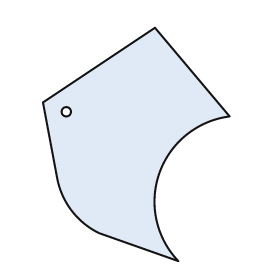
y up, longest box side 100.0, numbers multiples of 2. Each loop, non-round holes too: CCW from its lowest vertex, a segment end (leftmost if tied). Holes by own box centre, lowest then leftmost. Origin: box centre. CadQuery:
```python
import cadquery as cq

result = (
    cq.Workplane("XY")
    .moveTo(18.0, -50.0)
    .threePointArc((10.0, -12.0), (40.0, 12.0))
    .lineTo(8.0, 50.0)
    .lineTo(-40.0, 18.0)
    .lineTo(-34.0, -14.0)
    .threePointArc((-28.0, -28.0), (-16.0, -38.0))
    .close()
    .moveTo(-30.0, 14.0)
    .circle(2.0)
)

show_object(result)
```